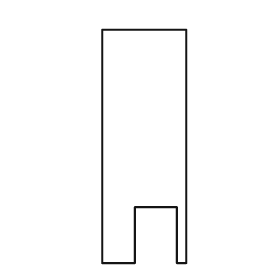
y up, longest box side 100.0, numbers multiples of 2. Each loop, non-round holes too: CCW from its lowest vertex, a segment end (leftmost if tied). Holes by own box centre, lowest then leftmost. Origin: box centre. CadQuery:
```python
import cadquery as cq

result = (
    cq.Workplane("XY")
    .moveTo(-18.0, -50.0)
    .lineTo(-4.0, -50.0)
    .lineTo(-4.0, -26.0)
    .lineTo(14.0, -26.0)
    .lineTo(14.0, -50.0)
    .lineTo(18.0, -50.0)
    .lineTo(18.0, 50.0)
    .lineTo(-18.0, 50.0)
    .close()
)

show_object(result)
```